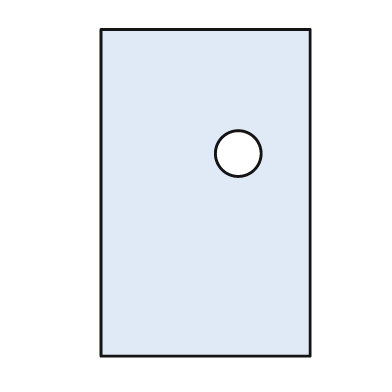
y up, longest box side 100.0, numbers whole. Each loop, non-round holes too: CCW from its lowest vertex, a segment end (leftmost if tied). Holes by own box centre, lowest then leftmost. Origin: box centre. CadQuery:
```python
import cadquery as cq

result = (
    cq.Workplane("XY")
    .moveTo(-32.0, -50.0)
    .lineTo(32.0, -50.0)
    .lineTo(32.0, 50.0)
    .lineTo(-32.0, 50.0)
    .close()
    .moveTo(10.0, 12.0)
    .circle(7.0)
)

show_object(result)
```